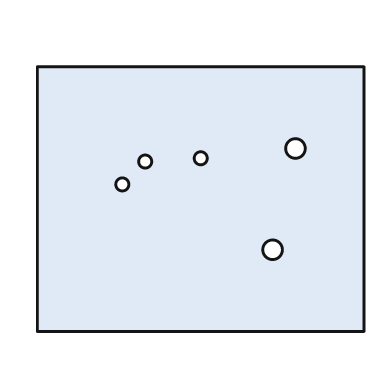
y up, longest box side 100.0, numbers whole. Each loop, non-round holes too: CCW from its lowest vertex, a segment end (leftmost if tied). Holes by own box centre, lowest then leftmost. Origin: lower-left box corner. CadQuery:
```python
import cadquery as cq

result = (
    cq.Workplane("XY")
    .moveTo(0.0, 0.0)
    .lineTo(100.0, 0.0)
    .lineTo(100.0, 81.0)
    .lineTo(0.0, 81.0)
    .close()
    .moveTo(72.0, 25.0)
    .circle(3.0)
    .moveTo(26.0, 45.0)
    .circle(2.0)
    .moveTo(33.0, 52.0)
    .circle(2.0)
    .moveTo(50.0, 53.0)
    .circle(2.0)
    .moveTo(79.0, 56.0)
    .circle(3.0)
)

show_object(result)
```